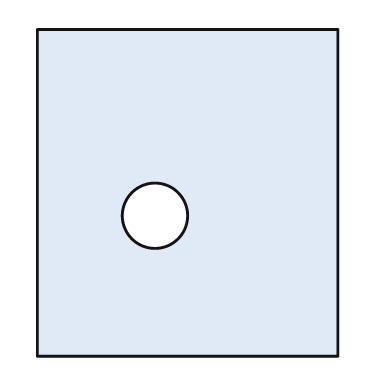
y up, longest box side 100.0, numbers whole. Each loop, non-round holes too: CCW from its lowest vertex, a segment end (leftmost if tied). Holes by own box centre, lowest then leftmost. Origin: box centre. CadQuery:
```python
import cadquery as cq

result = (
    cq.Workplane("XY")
    .moveTo(-46.0, -50.0)
    .lineTo(46.0, -50.0)
    .lineTo(46.0, 50.0)
    .lineTo(-46.0, 50.0)
    .close()
    .moveTo(-10.0, -7.0)
    .circle(10.0)
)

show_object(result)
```